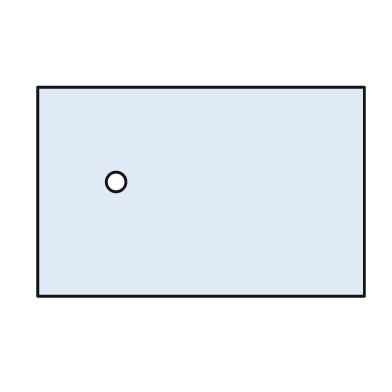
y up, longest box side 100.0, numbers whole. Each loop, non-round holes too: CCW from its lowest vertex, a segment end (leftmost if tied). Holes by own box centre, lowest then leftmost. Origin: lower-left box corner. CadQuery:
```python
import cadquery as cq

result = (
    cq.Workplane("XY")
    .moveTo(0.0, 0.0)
    .lineTo(100.0, 0.0)
    .lineTo(100.0, 64.0)
    .lineTo(0.0, 64.0)
    .close()
    .moveTo(24.0, 35.0)
    .circle(3.0)
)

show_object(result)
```